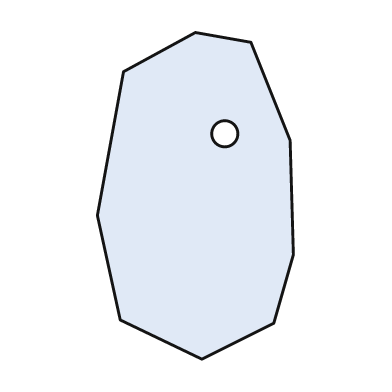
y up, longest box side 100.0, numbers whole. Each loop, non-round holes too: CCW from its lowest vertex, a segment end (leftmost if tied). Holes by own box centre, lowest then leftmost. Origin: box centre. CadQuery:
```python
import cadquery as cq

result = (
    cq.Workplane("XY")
    .moveTo(2.0, -50.0)
    .lineTo(24.0, -39.0)
    .lineTo(30.0, -18.0)
    .lineTo(29.0, 17.0)
    .lineTo(17.0, 47.0)
    .lineTo(0.0, 50.0)
    .lineTo(-22.0, 38.0)
    .lineTo(-30.0, -6.0)
    .lineTo(-23.0, -38.0)
    .close()
    .moveTo(9.0, 19.0)
    .circle(4.0)
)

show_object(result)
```